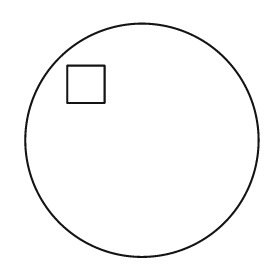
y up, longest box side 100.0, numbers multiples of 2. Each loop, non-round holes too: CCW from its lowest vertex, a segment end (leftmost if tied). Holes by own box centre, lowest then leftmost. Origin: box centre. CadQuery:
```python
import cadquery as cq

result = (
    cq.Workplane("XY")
    .moveTo(0.0, 0.0)
    .circle(50.0)
    .moveTo(-32.0, 16.0)
    .lineTo(-16.0, 16.0)
    .lineTo(-16.0, 32.0)
    .lineTo(-32.0, 32.0)
    .close()
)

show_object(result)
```